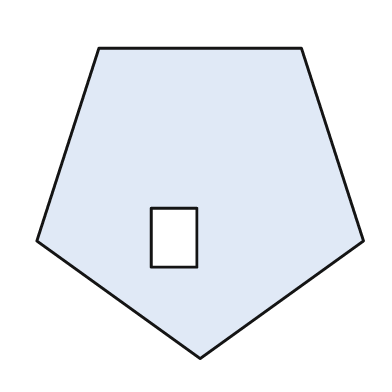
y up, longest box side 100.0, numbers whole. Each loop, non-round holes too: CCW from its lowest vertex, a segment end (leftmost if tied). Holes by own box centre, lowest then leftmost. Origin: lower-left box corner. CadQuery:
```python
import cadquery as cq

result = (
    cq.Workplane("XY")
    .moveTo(50.0, 0.0)
    .lineTo(100.0, 36.0)
    .lineTo(81.0, 95.0)
    .lineTo(19.0, 95.0)
    .lineTo(0.0, 36.0)
    .close()
    .moveTo(35.0, 28.0)
    .lineTo(49.0, 28.0)
    .lineTo(49.0, 46.0)
    .lineTo(35.0, 46.0)
    .close()
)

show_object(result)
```